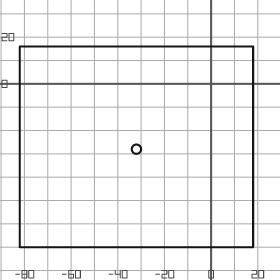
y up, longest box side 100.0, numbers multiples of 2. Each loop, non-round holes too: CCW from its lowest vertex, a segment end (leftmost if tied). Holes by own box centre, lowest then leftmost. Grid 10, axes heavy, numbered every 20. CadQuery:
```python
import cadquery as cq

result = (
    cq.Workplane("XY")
    .moveTo(-82.0, -70.0)
    .lineTo(18.0, -70.0)
    .lineTo(18.0, 16.0)
    .lineTo(-82.0, 16.0)
    .close()
    .moveTo(-32.0, -28.0)
    .circle(2.0)
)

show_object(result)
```